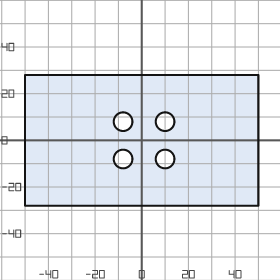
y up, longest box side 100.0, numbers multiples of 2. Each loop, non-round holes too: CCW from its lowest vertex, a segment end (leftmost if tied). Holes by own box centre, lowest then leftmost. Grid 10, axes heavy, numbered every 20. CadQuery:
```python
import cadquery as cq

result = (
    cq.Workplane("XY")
    .moveTo(-50.0, -28.0)
    .lineTo(50.0, -28.0)
    .lineTo(50.0, 28.0)
    .lineTo(-50.0, 28.0)
    .close()
    .moveTo(-8.0, -8.0)
    .circle(4.0)
    .moveTo(10.0, -8.0)
    .circle(4.0)
    .moveTo(-8.0, 8.0)
    .circle(4.0)
    .moveTo(10.0, 8.0)
    .circle(4.0)
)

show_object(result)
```